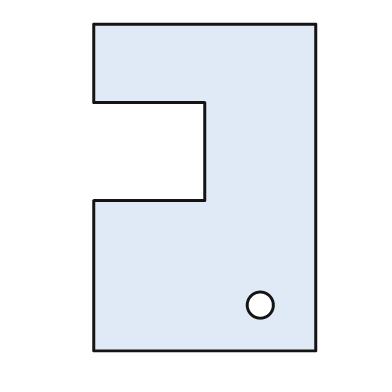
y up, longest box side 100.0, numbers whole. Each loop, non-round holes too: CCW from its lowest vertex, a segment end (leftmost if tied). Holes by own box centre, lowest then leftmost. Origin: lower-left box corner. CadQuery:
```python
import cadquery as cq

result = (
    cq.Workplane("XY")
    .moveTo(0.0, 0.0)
    .lineTo(68.0, 0.0)
    .lineTo(68.0, 100.0)
    .lineTo(0.0, 100.0)
    .lineTo(0.0, 76.0)
    .lineTo(34.0, 76.0)
    .lineTo(34.0, 46.0)
    .lineTo(0.0, 46.0)
    .close()
    .moveTo(51.0, 14.0)
    .circle(4.0)
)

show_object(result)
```